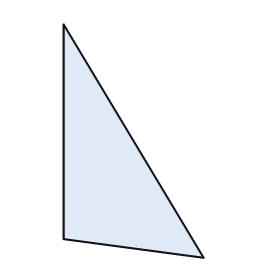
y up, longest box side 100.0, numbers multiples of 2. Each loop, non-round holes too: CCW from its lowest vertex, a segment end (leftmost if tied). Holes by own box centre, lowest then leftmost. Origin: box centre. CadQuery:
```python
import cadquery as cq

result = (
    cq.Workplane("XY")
    .moveTo(30.0, -50.0)
    .lineTo(-30.0, 50.0)
    .lineTo(-30.0, -42.0)
    .close()
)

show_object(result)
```